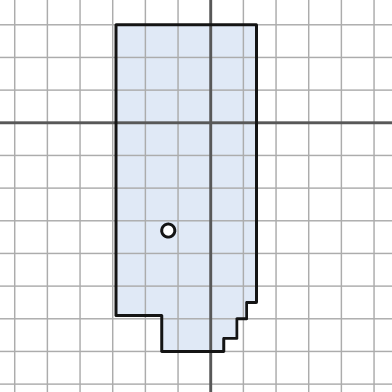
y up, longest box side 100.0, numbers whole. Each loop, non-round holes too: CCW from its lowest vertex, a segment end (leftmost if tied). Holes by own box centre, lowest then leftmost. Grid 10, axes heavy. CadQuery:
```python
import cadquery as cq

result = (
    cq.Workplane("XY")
    .moveTo(-15.0, -70.0)
    .lineTo(4.0, -70.0)
    .lineTo(4.0, -66.0)
    .lineTo(8.0, -66.0)
    .lineTo(8.0, -60.0)
    .lineTo(11.0, -60.0)
    .lineTo(11.0, -55.0)
    .lineTo(14.0, -55.0)
    .lineTo(14.0, 30.0)
    .lineTo(-29.0, 30.0)
    .lineTo(-29.0, -59.0)
    .lineTo(-15.0, -59.0)
    .close()
    .moveTo(-13.0, -33.0)
    .circle(2.0)
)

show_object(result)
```